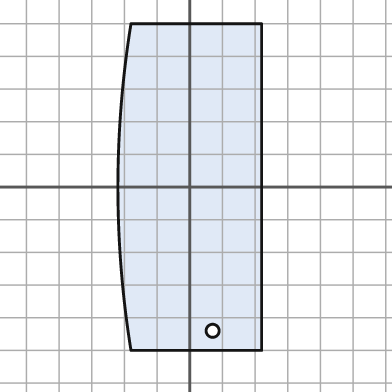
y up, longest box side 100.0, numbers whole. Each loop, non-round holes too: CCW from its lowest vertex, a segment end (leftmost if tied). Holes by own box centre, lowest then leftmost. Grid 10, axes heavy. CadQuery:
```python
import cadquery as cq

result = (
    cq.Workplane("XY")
    .moveTo(-18.0, -50.0)
    .lineTo(22.0, -50.0)
    .lineTo(22.0, 50.0)
    .lineTo(-18.0, 50.0)
    .threePointArc((-22.0, 0.0), (-18.0, -50.0))
    .close()
    .moveTo(7.0, -44.0)
    .circle(2.0)
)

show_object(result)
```